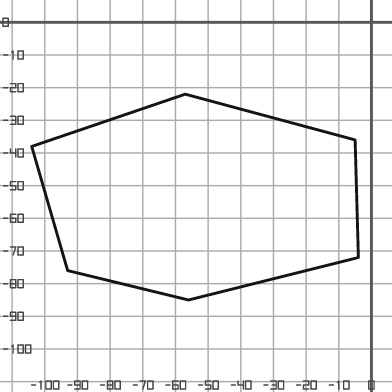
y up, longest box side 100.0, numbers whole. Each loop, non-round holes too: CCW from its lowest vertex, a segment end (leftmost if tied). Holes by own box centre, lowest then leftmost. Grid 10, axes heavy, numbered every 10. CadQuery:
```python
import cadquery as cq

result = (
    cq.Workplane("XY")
    .moveTo(-56.0, -85.0)
    .lineTo(-4.0, -72.0)
    .lineTo(-5.0, -36.0)
    .lineTo(-57.0, -22.0)
    .lineTo(-104.0, -38.0)
    .lineTo(-93.0, -76.0)
    .close()
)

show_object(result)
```